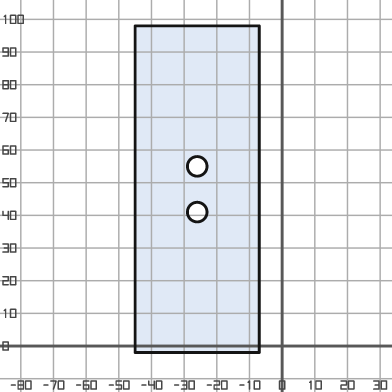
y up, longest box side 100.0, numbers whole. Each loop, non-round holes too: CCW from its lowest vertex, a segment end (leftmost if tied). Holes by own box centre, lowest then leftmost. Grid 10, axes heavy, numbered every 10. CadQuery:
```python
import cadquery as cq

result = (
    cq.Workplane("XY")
    .moveTo(-45.0, -2.0)
    .lineTo(-7.0, -2.0)
    .lineTo(-7.0, 98.0)
    .lineTo(-45.0, 98.0)
    .close()
    .moveTo(-26.0, 41.0)
    .circle(3.0)
    .moveTo(-26.0, 55.0)
    .circle(3.0)
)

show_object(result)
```